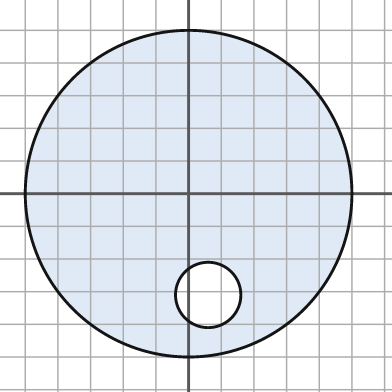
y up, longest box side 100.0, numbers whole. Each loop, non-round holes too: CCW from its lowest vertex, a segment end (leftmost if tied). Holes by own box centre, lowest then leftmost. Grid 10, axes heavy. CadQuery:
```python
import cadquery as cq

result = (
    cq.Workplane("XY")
    .moveTo(0.0, 0.0)
    .circle(50.0)
    .moveTo(6.0, -31.0)
    .circle(10.0)
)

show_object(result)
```